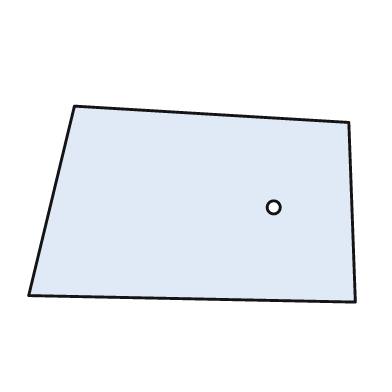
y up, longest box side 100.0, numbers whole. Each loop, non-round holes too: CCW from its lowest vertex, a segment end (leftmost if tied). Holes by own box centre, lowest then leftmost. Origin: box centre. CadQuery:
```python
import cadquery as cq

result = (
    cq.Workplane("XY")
    .moveTo(50.0, -30.0)
    .lineTo(48.0, 25.0)
    .lineTo(-36.0, 30.0)
    .lineTo(-50.0, -28.0)
    .close()
    .moveTo(25.0, -1.0)
    .circle(2.0)
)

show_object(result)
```